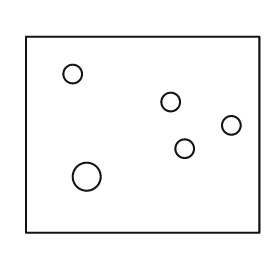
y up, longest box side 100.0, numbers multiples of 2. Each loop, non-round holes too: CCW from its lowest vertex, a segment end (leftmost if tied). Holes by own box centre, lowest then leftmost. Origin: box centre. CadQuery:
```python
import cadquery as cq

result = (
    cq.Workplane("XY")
    .moveTo(-50.0, -42.0)
    .lineTo(50.0, -42.0)
    .lineTo(50.0, 42.0)
    .lineTo(-50.0, 42.0)
    .close()
    .moveTo(-24.0, -18.0)
    .circle(6.0)
    .moveTo(18.0, -6.0)
    .circle(4.0)
    .moveTo(38.0, 4.0)
    .circle(4.0)
    .moveTo(12.0, 14.0)
    .circle(4.0)
    .moveTo(-30.0, 26.0)
    .circle(4.0)
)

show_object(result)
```